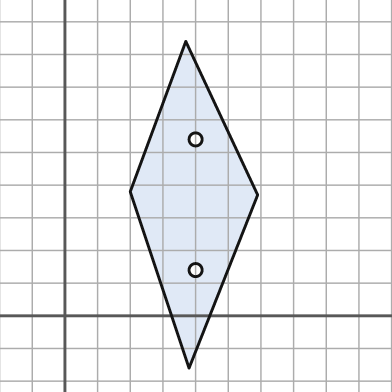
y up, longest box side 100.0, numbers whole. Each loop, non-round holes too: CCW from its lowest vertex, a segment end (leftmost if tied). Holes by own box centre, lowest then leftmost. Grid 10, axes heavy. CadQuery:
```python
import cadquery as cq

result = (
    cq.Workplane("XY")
    .moveTo(38.0, -16.0)
    .lineTo(59.0, 37.0)
    .lineTo(37.0, 84.0)
    .lineTo(20.0, 38.0)
    .close()
    .moveTo(40.0, 14.0)
    .circle(2.0)
    .moveTo(40.0, 54.0)
    .circle(2.0)
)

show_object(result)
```